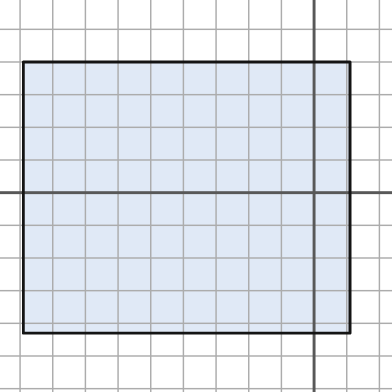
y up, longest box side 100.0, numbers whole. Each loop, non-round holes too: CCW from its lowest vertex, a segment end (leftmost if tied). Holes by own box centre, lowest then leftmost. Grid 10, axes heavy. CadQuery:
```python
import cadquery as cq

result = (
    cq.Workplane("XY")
    .moveTo(-89.0, -43.0)
    .lineTo(11.0, -43.0)
    .lineTo(11.0, 40.0)
    .lineTo(-89.0, 40.0)
    .close()
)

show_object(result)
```